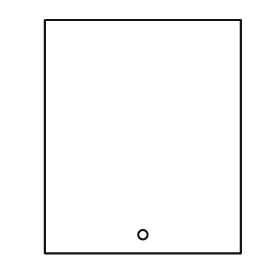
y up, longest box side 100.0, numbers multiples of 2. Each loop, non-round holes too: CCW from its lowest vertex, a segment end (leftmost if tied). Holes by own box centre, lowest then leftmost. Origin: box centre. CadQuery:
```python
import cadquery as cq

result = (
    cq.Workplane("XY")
    .moveTo(-42.0, -50.0)
    .lineTo(42.0, -50.0)
    .lineTo(42.0, 50.0)
    .lineTo(-42.0, 50.0)
    .close()
    .moveTo(0.0, -42.0)
    .circle(2.0)
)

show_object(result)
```